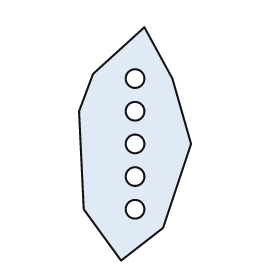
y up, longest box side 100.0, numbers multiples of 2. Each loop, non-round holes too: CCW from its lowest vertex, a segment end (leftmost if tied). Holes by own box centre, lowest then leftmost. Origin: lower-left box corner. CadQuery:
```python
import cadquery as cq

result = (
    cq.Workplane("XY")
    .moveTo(18.0, 0.0)
    .lineTo(36.0, 14.0)
    .lineTo(48.0, 50.0)
    .lineTo(40.0, 78.0)
    .lineTo(28.0, 100.0)
    .lineTo(6.0, 80.0)
    .lineTo(0.0, 64.0)
    .lineTo(2.0, 22.0)
    .close()
    .moveTo(24.0, 22.0)
    .circle(4.0)
    .moveTo(24.0, 36.0)
    .circle(4.0)
    .moveTo(24.0, 50.0)
    .circle(4.0)
    .moveTo(24.0, 64.0)
    .circle(4.0)
    .moveTo(24.0, 78.0)
    .circle(4.0)
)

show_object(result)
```